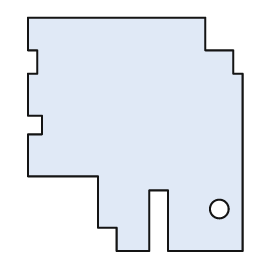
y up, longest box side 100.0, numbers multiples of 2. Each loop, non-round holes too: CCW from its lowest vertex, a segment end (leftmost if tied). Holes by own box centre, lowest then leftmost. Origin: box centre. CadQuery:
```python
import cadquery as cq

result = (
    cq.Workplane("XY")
    .moveTo(-8.0, -50.0)
    .lineTo(6.0, -50.0)
    .lineTo(6.0, -24.0)
    .lineTo(14.0, -24.0)
    .lineTo(14.0, -50.0)
    .lineTo(46.0, -50.0)
    .lineTo(46.0, 26.0)
    .lineTo(42.0, 26.0)
    .lineTo(42.0, 36.0)
    .lineTo(30.0, 36.0)
    .lineTo(30.0, 50.0)
    .lineTo(-46.0, 50.0)
    .lineTo(-46.0, 36.0)
    .lineTo(-42.0, 36.0)
    .lineTo(-42.0, 26.0)
    .lineTo(-46.0, 26.0)
    .lineTo(-46.0, 8.0)
    .lineTo(-40.0, 8.0)
    .lineTo(-40.0, 0.0)
    .lineTo(-46.0, 0.0)
    .lineTo(-46.0, -18.0)
    .lineTo(-16.0, -18.0)
    .lineTo(-16.0, -40.0)
    .lineTo(-8.0, -40.0)
    .close()
    .moveTo(36.0, -32.0)
    .circle(4.0)
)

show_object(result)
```